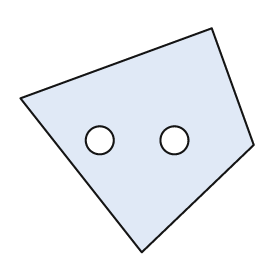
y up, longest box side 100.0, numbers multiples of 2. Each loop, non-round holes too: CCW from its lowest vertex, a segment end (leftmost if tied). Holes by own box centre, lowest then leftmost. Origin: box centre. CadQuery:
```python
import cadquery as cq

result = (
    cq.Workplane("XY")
    .moveTo(2.0, -48.0)
    .lineTo(50.0, -2.0)
    .lineTo(32.0, 48.0)
    .lineTo(-50.0, 18.0)
    .close()
    .moveTo(-16.0, 0.0)
    .circle(6.0)
    .moveTo(16.0, 0.0)
    .circle(6.0)
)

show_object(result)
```